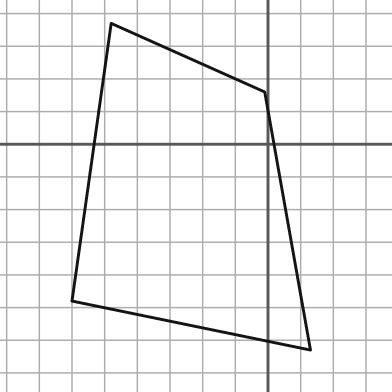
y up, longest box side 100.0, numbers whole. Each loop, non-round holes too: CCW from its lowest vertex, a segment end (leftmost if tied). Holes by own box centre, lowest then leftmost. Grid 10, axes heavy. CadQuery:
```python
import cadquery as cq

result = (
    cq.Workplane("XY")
    .moveTo(13.0, -63.0)
    .lineTo(-1.0, 16.0)
    .lineTo(-48.0, 37.0)
    .lineTo(-60.0, -48.0)
    .close()
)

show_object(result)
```